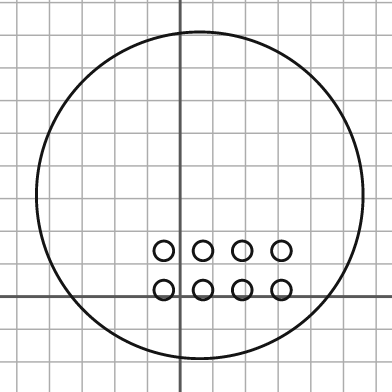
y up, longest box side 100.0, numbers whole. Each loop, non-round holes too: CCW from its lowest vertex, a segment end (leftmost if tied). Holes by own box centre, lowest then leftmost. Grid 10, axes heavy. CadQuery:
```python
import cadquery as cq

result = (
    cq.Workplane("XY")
    .moveTo(6.0, 31.0)
    .circle(50.0)
    .moveTo(-5.0, 2.0)
    .circle(3.0)
    .moveTo(7.0, 2.0)
    .circle(3.0)
    .moveTo(19.0, 2.0)
    .circle(3.0)
    .moveTo(31.0, 2.0)
    .circle(3.0)
    .moveTo(-5.0, 14.0)
    .circle(3.0)
    .moveTo(7.0, 14.0)
    .circle(3.0)
    .moveTo(19.0, 14.0)
    .circle(3.0)
    .moveTo(31.0, 14.0)
    .circle(3.0)
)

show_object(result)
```